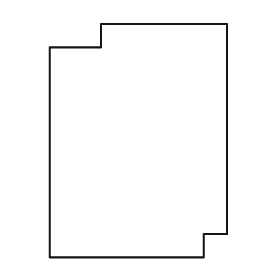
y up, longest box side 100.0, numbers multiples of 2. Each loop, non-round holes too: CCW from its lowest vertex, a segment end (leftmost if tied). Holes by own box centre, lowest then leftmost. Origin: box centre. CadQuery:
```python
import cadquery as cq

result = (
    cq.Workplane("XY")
    .moveTo(-38.0, -50.0)
    .lineTo(28.0, -50.0)
    .lineTo(28.0, -40.0)
    .lineTo(38.0, -40.0)
    .lineTo(38.0, 50.0)
    .lineTo(-16.0, 50.0)
    .lineTo(-16.0, 40.0)
    .lineTo(-38.0, 40.0)
    .close()
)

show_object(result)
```